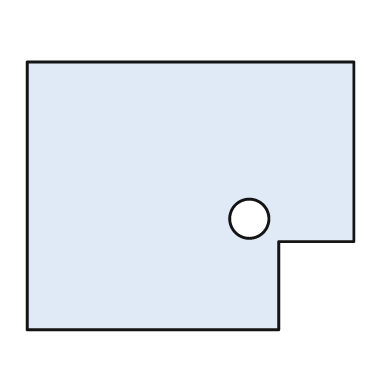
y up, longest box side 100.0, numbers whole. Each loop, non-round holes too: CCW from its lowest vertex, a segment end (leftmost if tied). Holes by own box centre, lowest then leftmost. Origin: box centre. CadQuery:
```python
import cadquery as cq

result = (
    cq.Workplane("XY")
    .moveTo(-50.0, -41.0)
    .lineTo(27.0, -41.0)
    .lineTo(27.0, -14.0)
    .lineTo(50.0, -14.0)
    .lineTo(50.0, 41.0)
    .lineTo(-50.0, 41.0)
    .close()
    .moveTo(18.0, -7.0)
    .circle(6.0)
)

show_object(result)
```